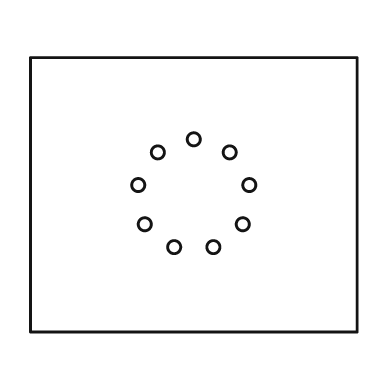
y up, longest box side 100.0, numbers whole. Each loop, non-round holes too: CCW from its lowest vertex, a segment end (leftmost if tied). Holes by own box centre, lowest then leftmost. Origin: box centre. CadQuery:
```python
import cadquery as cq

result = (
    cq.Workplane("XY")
    .moveTo(-50.0, -42.0)
    .lineTo(50.0, -42.0)
    .lineTo(50.0, 42.0)
    .lineTo(-50.0, 42.0)
    .close()
    .moveTo(-6.0, -16.0)
    .circle(2.0)
    .moveTo(6.0, -16.0)
    .circle(2.0)
    .moveTo(-15.0, -9.0)
    .circle(2.0)
    .moveTo(15.0, -9.0)
    .circle(2.0)
    .moveTo(-17.0, 3.0)
    .circle(2.0)
    .moveTo(17.0, 3.0)
    .circle(2.0)
    .moveTo(-11.0, 13.0)
    .circle(2.0)
    .moveTo(11.0, 13.0)
    .circle(2.0)
    .moveTo(0.0, 17.0)
    .circle(2.0)
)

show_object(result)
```